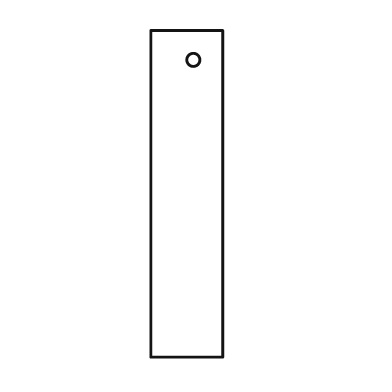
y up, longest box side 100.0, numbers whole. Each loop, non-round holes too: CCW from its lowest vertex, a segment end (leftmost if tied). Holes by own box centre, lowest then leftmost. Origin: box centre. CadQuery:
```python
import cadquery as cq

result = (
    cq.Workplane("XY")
    .moveTo(-11.0, -50.0)
    .lineTo(11.0, -50.0)
    .lineTo(11.0, 50.0)
    .lineTo(-11.0, 50.0)
    .close()
    .moveTo(2.0, 41.0)
    .circle(2.0)
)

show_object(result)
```